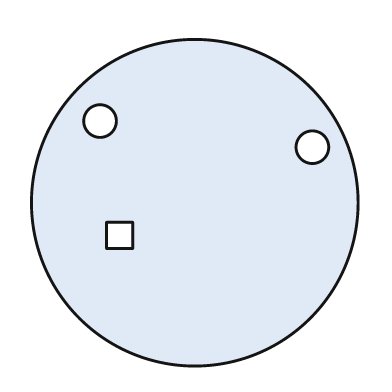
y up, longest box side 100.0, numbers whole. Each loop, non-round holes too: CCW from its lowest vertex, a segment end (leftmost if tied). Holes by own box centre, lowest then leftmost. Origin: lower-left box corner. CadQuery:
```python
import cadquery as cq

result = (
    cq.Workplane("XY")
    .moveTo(50.0, 50.0)
    .circle(50.0)
    .moveTo(23.0, 36.0)
    .lineTo(31.0, 36.0)
    .lineTo(31.0, 44.0)
    .lineTo(23.0, 44.0)
    .close()
    .moveTo(86.0, 67.0)
    .circle(5.0)
    .moveTo(21.0, 75.0)
    .circle(5.0)
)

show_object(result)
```